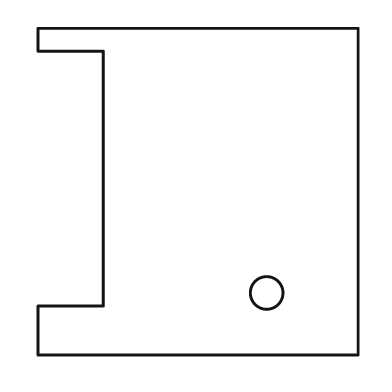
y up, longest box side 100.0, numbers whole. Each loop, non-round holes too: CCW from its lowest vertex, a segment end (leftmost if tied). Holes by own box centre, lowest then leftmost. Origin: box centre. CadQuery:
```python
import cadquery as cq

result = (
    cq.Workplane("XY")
    .moveTo(-49.0, -50.0)
    .lineTo(49.0, -50.0)
    .lineTo(49.0, 50.0)
    .lineTo(-49.0, 50.0)
    .lineTo(-49.0, 43.0)
    .lineTo(-29.0, 43.0)
    .lineTo(-29.0, -35.0)
    .lineTo(-49.0, -35.0)
    .close()
    .moveTo(21.0, -31.0)
    .circle(5.0)
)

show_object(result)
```